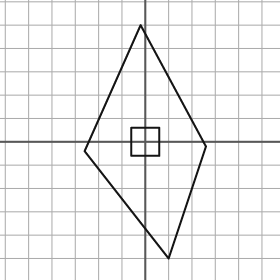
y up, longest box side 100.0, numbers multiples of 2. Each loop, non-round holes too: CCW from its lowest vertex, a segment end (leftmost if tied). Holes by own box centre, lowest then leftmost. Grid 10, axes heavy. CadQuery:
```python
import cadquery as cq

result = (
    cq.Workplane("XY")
    .moveTo(10.0, -50.0)
    .lineTo(26.0, -2.0)
    .lineTo(-2.0, 50.0)
    .lineTo(-26.0, -4.0)
    .close()
    .moveTo(-6.0, -6.0)
    .lineTo(6.0, -6.0)
    .lineTo(6.0, 6.0)
    .lineTo(-6.0, 6.0)
    .close()
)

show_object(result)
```